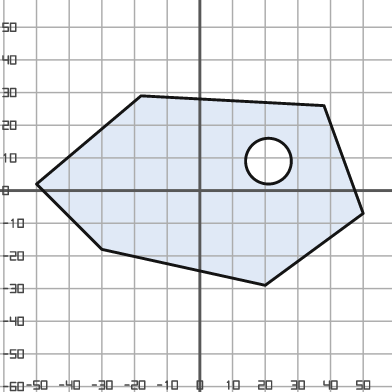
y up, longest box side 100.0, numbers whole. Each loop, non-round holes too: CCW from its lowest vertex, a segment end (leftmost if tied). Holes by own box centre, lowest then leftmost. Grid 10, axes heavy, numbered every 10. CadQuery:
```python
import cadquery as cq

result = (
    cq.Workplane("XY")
    .moveTo(20.0, -29.0)
    .lineTo(50.0, -7.0)
    .lineTo(38.0, 26.0)
    .lineTo(-18.0, 29.0)
    .lineTo(-50.0, 2.0)
    .lineTo(-30.0, -18.0)
    .close()
    .moveTo(21.0, 9.0)
    .circle(7.0)
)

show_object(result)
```